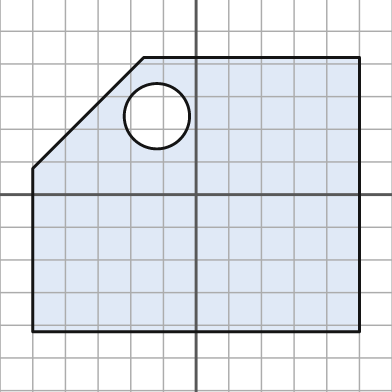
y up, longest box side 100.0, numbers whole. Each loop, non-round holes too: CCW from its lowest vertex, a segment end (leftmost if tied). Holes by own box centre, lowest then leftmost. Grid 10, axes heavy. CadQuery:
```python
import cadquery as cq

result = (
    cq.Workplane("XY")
    .moveTo(-50.0, -42.0)
    .lineTo(50.0, -42.0)
    .lineTo(50.0, 42.0)
    .lineTo(-16.0, 42.0)
    .lineTo(-50.0, 8.0)
    .close()
    .moveTo(-12.0, 24.0)
    .circle(10.0)
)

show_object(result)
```